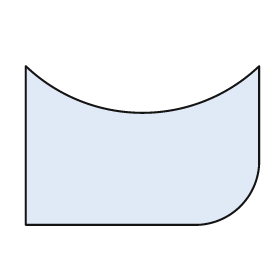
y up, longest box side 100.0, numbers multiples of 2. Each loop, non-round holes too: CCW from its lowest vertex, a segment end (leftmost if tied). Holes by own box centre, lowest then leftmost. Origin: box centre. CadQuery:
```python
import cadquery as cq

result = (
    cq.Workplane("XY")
    .moveTo(-50.0, -34.0)
    .lineTo(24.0, -34.0)
    .threePointArc((42.0, -26.0), (50.0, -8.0))
    .lineTo(50.0, 34.0)
    .threePointArc((0.0, 14.0), (-50.0, 34.0))
    .close()
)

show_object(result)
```